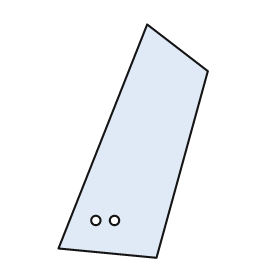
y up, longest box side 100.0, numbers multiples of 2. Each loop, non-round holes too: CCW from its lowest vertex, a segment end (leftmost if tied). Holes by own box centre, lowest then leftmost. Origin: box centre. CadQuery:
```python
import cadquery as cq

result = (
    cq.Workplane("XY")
    .moveTo(10.0, -50.0)
    .lineTo(32.0, 30.0)
    .lineTo(6.0, 50.0)
    .lineTo(-32.0, -46.0)
    .close()
    .moveTo(-16.0, -34.0)
    .circle(2.0)
    .moveTo(-8.0, -34.0)
    .circle(2.0)
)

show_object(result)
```